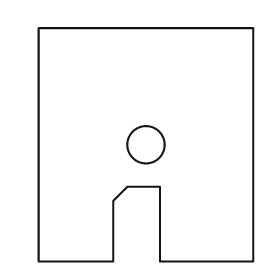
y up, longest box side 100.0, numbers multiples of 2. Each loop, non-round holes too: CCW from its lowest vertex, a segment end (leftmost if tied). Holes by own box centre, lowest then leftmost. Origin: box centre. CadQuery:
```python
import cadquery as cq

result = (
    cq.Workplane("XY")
    .moveTo(-46.0, -50.0)
    .lineTo(-14.0, -50.0)
    .lineTo(-14.0, -24.0)
    .lineTo(-8.0, -18.0)
    .lineTo(6.0, -18.0)
    .lineTo(6.0, -50.0)
    .lineTo(46.0, -50.0)
    .lineTo(46.0, 50.0)
    .lineTo(-46.0, 50.0)
    .close()
    .moveTo(0.0, 0.0)
    .circle(8.0)
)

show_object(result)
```